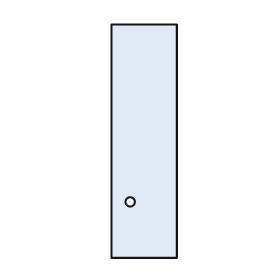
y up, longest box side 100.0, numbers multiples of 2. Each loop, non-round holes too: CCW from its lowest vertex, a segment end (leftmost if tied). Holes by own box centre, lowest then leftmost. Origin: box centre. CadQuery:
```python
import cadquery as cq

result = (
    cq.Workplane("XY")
    .moveTo(-14.0, -50.0)
    .lineTo(14.0, -50.0)
    .lineTo(14.0, 50.0)
    .lineTo(-14.0, 50.0)
    .close()
    .moveTo(-6.0, -26.0)
    .circle(2.0)
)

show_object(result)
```